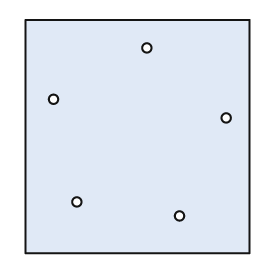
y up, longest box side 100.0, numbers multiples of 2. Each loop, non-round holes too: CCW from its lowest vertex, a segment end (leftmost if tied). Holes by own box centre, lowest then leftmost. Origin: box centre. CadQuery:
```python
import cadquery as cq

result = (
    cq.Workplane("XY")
    .moveTo(-48.0, -50.0)
    .lineTo(48.0, -50.0)
    .lineTo(48.0, 50.0)
    .lineTo(-48.0, 50.0)
    .close()
    .moveTo(18.0, -34.0)
    .circle(2.0)
    .moveTo(-26.0, -28.0)
    .circle(2.0)
    .moveTo(38.0, 8.0)
    .circle(2.0)
    .moveTo(-36.0, 16.0)
    .circle(2.0)
    .moveTo(4.0, 38.0)
    .circle(2.0)
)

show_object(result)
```